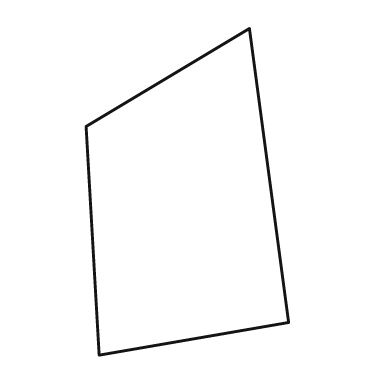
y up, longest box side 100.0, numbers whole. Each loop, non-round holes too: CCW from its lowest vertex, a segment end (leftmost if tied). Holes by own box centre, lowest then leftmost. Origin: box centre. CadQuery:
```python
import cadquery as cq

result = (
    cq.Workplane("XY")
    .moveTo(-27.0, -50.0)
    .lineTo(31.0, -40.0)
    .lineTo(19.0, 50.0)
    .lineTo(-31.0, 20.0)
    .close()
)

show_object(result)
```